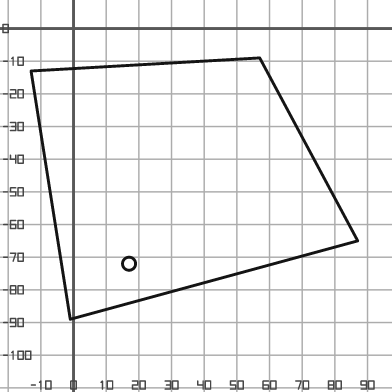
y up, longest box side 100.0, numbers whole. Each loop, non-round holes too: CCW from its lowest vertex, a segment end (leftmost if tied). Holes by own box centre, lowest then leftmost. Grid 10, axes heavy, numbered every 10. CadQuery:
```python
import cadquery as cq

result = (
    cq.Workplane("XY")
    .moveTo(-1.0, -89.0)
    .lineTo(87.0, -65.0)
    .lineTo(57.0, -9.0)
    .lineTo(-13.0, -13.0)
    .close()
    .moveTo(17.0, -72.0)
    .circle(2.0)
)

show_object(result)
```